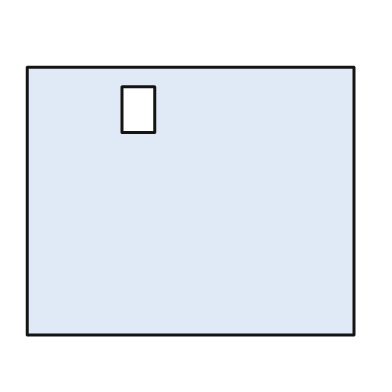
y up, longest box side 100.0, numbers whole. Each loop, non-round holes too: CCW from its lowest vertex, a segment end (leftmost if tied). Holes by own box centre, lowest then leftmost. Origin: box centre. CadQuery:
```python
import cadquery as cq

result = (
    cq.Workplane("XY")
    .moveTo(-50.0, -41.0)
    .lineTo(50.0, -41.0)
    .lineTo(50.0, 41.0)
    .lineTo(-50.0, 41.0)
    .close()
    .moveTo(-21.0, 21.0)
    .lineTo(-11.0, 21.0)
    .lineTo(-11.0, 35.0)
    .lineTo(-21.0, 35.0)
    .close()
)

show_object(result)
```